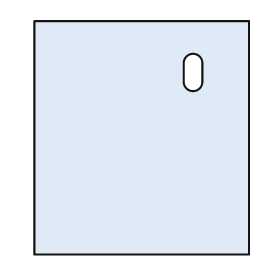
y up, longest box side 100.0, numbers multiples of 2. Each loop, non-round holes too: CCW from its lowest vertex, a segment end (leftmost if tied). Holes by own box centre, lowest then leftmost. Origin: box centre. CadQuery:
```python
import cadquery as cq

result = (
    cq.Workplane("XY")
    .moveTo(-46.0, -50.0)
    .lineTo(46.0, -50.0)
    .lineTo(46.0, 50.0)
    .lineTo(-46.0, 50.0)
    .close()
    .moveTo(18.0, 24.0)
    .threePointArc((22.0, 20.0), (26.0, 24.0))
    .lineTo(26.0, 32.0)
    .threePointArc((22.0, 36.0), (18.0, 32.0))
    .close()
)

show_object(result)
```